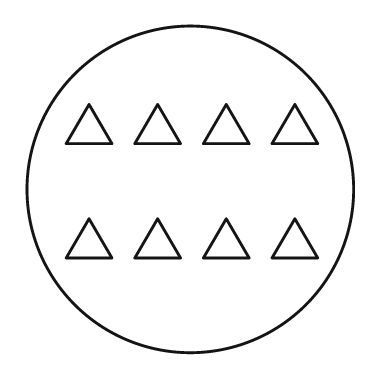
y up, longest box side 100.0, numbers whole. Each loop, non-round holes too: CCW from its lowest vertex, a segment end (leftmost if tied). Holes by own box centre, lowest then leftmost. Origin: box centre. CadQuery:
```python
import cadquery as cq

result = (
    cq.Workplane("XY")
    .moveTo(0.0, 0.0)
    .circle(50.0)
    .moveTo(-38.0, -21.0)
    .lineTo(-24.0, -21.0)
    .lineTo(-31.0, -9.0)
    .close()
    .moveTo(-17.0, -21.0)
    .lineTo(-3.0, -21.0)
    .lineTo(-10.0, -9.0)
    .close()
    .moveTo(4.0, -21.0)
    .lineTo(18.0, -21.0)
    .lineTo(11.0, -9.0)
    .close()
    .moveTo(25.0, -21.0)
    .lineTo(39.0, -21.0)
    .lineTo(32.0, -9.0)
    .close()
    .moveTo(-38.0, 14.0)
    .lineTo(-24.0, 14.0)
    .lineTo(-31.0, 26.0)
    .close()
    .moveTo(-17.0, 14.0)
    .lineTo(-3.0, 14.0)
    .lineTo(-10.0, 26.0)
    .close()
    .moveTo(4.0, 14.0)
    .lineTo(18.0, 14.0)
    .lineTo(11.0, 26.0)
    .close()
    .moveTo(25.0, 14.0)
    .lineTo(39.0, 14.0)
    .lineTo(32.0, 26.0)
    .close()
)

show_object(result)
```